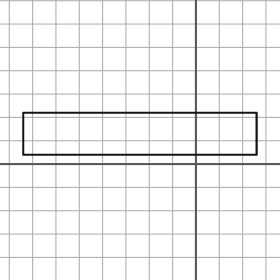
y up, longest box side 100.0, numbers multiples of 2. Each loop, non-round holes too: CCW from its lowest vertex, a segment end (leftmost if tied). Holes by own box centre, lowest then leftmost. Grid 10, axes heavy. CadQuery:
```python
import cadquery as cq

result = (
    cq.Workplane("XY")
    .moveTo(-74.0, 4.0)
    .lineTo(26.0, 4.0)
    .lineTo(26.0, 22.0)
    .lineTo(-74.0, 22.0)
    .close()
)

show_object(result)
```